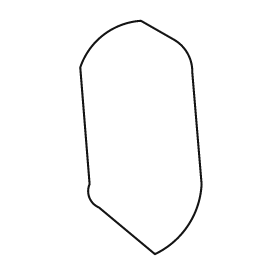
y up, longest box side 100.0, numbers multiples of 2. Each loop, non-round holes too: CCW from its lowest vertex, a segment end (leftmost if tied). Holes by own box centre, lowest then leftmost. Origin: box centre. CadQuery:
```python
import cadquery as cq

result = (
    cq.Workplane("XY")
    .moveTo(6.0, -50.0)
    .threePointArc((20.0, -38.0), (26.0, -20.0))
    .lineTo(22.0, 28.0)
    .threePointArc((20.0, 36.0), (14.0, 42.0))
    .lineTo(0.0, 50.0)
    .threePointArc((-16.0, 44.0), (-26.0, 30.0))
    .lineTo(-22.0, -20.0)
    .threePointArc((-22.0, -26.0), (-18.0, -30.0))
    .close()
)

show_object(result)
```